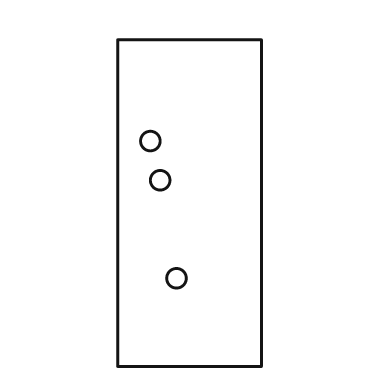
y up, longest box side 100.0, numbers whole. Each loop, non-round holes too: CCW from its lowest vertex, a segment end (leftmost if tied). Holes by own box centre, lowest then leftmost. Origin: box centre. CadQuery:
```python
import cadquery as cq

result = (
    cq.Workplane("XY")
    .moveTo(-22.0, -50.0)
    .lineTo(22.0, -50.0)
    .lineTo(22.0, 50.0)
    .lineTo(-22.0, 50.0)
    .close()
    .moveTo(-4.0, -23.0)
    .circle(3.0)
    .moveTo(-9.0, 7.0)
    .circle(3.0)
    .moveTo(-12.0, 19.0)
    .circle(3.0)
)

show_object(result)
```